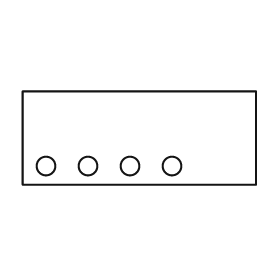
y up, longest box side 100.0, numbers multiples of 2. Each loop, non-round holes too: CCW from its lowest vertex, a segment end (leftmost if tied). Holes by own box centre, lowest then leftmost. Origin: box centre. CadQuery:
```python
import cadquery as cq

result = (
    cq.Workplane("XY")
    .moveTo(-50.0, -20.0)
    .lineTo(50.0, -20.0)
    .lineTo(50.0, 20.0)
    .lineTo(-50.0, 20.0)
    .close()
    .moveTo(-40.0, -12.0)
    .circle(4.0)
    .moveTo(-22.0, -12.0)
    .circle(4.0)
    .moveTo(-4.0, -12.0)
    .circle(4.0)
    .moveTo(14.0, -12.0)
    .circle(4.0)
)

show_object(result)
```